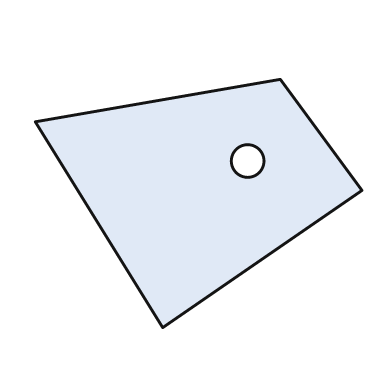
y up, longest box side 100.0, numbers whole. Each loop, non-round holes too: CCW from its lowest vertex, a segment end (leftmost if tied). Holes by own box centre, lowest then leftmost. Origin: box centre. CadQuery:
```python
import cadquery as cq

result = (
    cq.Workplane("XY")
    .moveTo(-11.0, -38.0)
    .lineTo(50.0, 4.0)
    .lineTo(25.0, 38.0)
    .lineTo(-50.0, 25.0)
    .close()
    .moveTo(15.0, 13.0)
    .circle(5.0)
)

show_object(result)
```